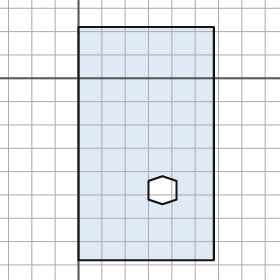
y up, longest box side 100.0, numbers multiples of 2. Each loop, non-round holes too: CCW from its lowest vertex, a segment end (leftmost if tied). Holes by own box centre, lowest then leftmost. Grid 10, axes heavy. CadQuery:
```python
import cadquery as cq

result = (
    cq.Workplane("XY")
    .moveTo(0.0, -78.0)
    .lineTo(58.0, -78.0)
    .lineTo(58.0, 22.0)
    .lineTo(0.0, 22.0)
    .close()
    .moveTo(36.0, -54.0)
    .lineTo(42.0, -52.0)
    .lineTo(42.0, -44.0)
    .lineTo(36.0, -42.0)
    .lineTo(30.0, -44.0)
    .lineTo(30.0, -52.0)
    .close()
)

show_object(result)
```